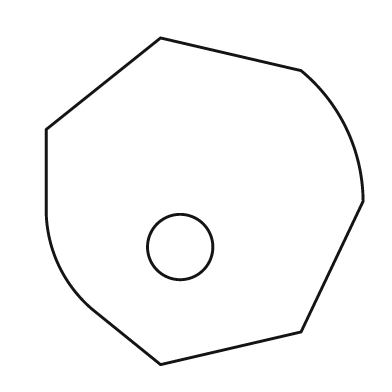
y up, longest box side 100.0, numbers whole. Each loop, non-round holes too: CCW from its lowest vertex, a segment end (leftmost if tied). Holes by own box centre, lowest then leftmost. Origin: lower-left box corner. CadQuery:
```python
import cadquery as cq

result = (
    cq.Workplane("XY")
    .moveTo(35.0, 0.0)
    .lineTo(78.0, 10.0)
    .lineTo(97.0, 50.0)
    .threePointArc((92.0, 72.0), (78.0, 90.0))
    .lineTo(35.0, 100.0)
    .lineTo(0.0, 72.0)
    .lineTo(0.0, 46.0)
    .threePointArc((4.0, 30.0), (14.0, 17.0))
    .close()
    .moveTo(41.0, 36.0)
    .circle(10.0)
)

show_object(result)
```